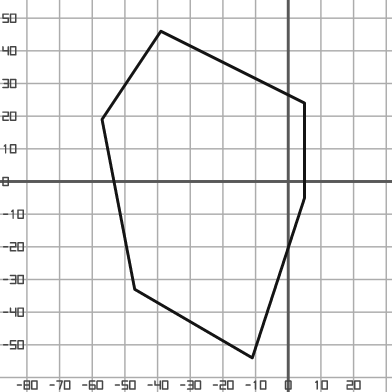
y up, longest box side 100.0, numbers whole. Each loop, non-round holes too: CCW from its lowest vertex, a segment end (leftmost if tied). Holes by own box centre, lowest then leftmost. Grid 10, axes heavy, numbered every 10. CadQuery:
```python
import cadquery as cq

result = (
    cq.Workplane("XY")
    .moveTo(-11.0, -54.0)
    .lineTo(5.0, -5.0)
    .lineTo(5.0, 24.0)
    .lineTo(-39.0, 46.0)
    .lineTo(-57.0, 19.0)
    .lineTo(-47.0, -33.0)
    .close()
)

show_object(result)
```